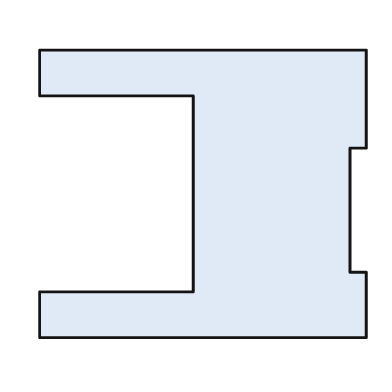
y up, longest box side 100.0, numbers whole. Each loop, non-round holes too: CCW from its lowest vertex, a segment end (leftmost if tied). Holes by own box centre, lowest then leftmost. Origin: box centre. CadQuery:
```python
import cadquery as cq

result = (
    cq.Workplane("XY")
    .moveTo(-50.0, -44.0)
    .lineTo(50.0, -44.0)
    .lineTo(50.0, -24.0)
    .lineTo(45.0, -24.0)
    .lineTo(45.0, 14.0)
    .lineTo(50.0, 14.0)
    .lineTo(50.0, 44.0)
    .lineTo(-50.0, 44.0)
    .lineTo(-50.0, 30.0)
    .lineTo(-3.0, 30.0)
    .lineTo(-3.0, -30.0)
    .lineTo(-50.0, -30.0)
    .close()
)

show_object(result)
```